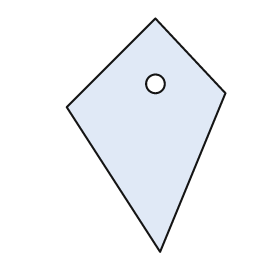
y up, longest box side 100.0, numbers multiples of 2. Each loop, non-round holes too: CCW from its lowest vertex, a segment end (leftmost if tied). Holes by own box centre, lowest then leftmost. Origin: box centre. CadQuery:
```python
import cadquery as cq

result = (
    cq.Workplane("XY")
    .moveTo(6.0, -50.0)
    .lineTo(34.0, 18.0)
    .lineTo(4.0, 50.0)
    .lineTo(-34.0, 12.0)
    .close()
    .moveTo(4.0, 22.0)
    .circle(4.0)
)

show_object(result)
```